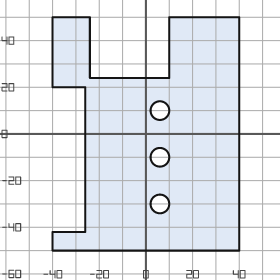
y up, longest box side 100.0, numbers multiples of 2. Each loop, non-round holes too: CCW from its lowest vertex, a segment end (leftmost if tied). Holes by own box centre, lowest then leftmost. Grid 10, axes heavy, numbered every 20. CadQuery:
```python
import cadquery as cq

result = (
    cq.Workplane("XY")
    .moveTo(-40.0, -50.0)
    .lineTo(40.0, -50.0)
    .lineTo(40.0, 50.0)
    .lineTo(10.0, 50.0)
    .lineTo(10.0, 24.0)
    .lineTo(-24.0, 24.0)
    .lineTo(-24.0, 50.0)
    .lineTo(-40.0, 50.0)
    .lineTo(-40.0, 20.0)
    .lineTo(-26.0, 20.0)
    .lineTo(-26.0, -42.0)
    .lineTo(-40.0, -42.0)
    .close()
    .moveTo(6.0, -30.0)
    .circle(4.0)
    .moveTo(6.0, -10.0)
    .circle(4.0)
    .moveTo(6.0, 10.0)
    .circle(4.0)
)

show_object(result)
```